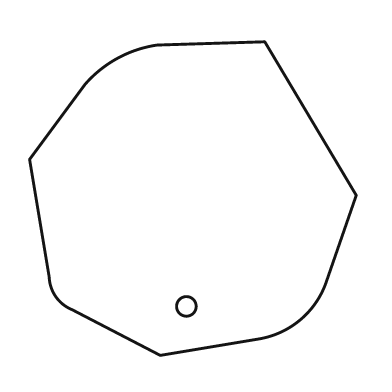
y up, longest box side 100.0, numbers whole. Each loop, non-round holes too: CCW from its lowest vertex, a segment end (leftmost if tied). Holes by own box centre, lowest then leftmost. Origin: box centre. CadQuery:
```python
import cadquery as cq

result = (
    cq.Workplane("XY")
    .moveTo(-10.0, -48.0)
    .lineTo(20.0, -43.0)
    .threePointArc((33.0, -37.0), (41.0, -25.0))
    .lineTo(50.0, 1.0)
    .lineTo(22.0, 48.0)
    .lineTo(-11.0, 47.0)
    .threePointArc((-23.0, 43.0), (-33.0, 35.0))
    .lineTo(-50.0, 12.0)
    .lineTo(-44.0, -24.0)
    .threePointArc((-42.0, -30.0), (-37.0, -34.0))
    .close()
    .moveTo(-2.0, -33.0)
    .circle(3.0)
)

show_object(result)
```